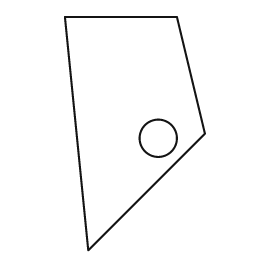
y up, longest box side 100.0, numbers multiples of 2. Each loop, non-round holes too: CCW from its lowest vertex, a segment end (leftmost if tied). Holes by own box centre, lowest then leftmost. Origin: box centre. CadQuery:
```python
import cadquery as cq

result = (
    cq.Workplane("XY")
    .moveTo(-20.0, -50.0)
    .lineTo(30.0, 0.0)
    .lineTo(18.0, 50.0)
    .lineTo(-30.0, 50.0)
    .close()
    .moveTo(10.0, -2.0)
    .circle(8.0)
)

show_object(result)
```